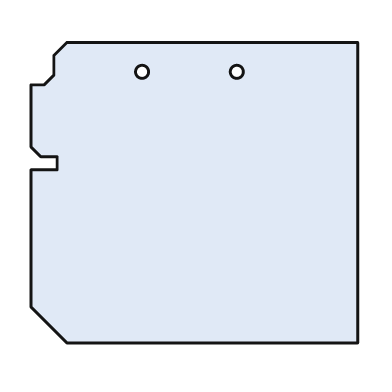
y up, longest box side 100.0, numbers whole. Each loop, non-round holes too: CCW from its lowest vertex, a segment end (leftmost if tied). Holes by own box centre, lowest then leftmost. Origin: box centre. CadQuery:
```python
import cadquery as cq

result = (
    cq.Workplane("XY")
    .moveTo(-39.0, -46.0)
    .lineTo(50.0, -46.0)
    .lineTo(50.0, 46.0)
    .lineTo(-39.0, 46.0)
    .lineTo(-43.0, 42.0)
    .lineTo(-43.0, 36.0)
    .lineTo(-46.0, 33.0)
    .lineTo(-50.0, 33.0)
    .lineTo(-50.0, 14.0)
    .lineTo(-47.0, 11.0)
    .lineTo(-42.0, 11.0)
    .lineTo(-42.0, 7.0)
    .lineTo(-50.0, 7.0)
    .lineTo(-50.0, -35.0)
    .close()
    .moveTo(-16.0, 37.0)
    .circle(2.0)
    .moveTo(13.0, 37.0)
    .circle(2.0)
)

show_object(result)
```